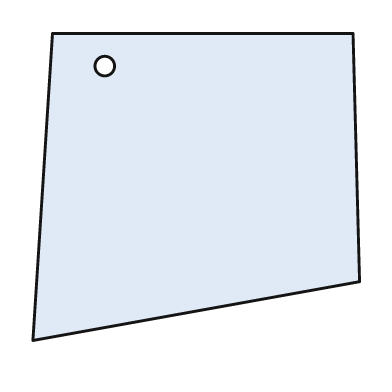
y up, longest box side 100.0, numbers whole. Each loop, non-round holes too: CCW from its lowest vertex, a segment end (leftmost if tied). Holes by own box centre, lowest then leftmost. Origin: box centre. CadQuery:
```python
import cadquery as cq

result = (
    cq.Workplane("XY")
    .moveTo(-50.0, -47.0)
    .lineTo(50.0, -29.0)
    .lineTo(48.0, 47.0)
    .lineTo(-44.0, 47.0)
    .close()
    .moveTo(-28.0, 37.0)
    .circle(3.0)
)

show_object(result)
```